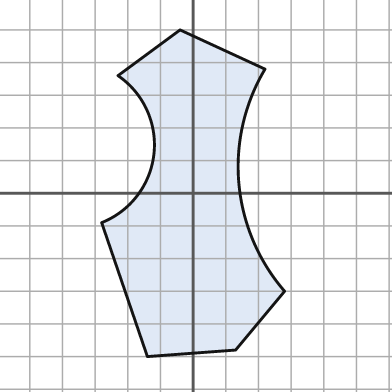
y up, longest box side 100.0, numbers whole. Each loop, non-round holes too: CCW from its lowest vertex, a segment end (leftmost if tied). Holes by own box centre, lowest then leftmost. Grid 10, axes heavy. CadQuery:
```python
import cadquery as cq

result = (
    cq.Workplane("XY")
    .moveTo(-14.0, -50.0)
    .lineTo(13.0, -48.0)
    .lineTo(28.0, -30.0)
    .threePointArc((14.0, 3.0), (22.0, 38.0))
    .lineTo(-4.0, 50.0)
    .lineTo(-23.0, 36.0)
    .threePointArc((-12.0, 12.0), (-28.0, -9.0))
    .close()
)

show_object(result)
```